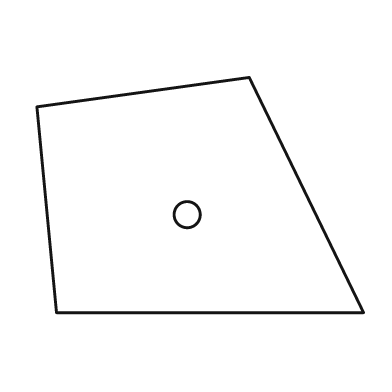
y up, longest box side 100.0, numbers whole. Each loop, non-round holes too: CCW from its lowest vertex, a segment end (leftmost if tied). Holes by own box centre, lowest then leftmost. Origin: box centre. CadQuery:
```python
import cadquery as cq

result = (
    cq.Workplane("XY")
    .moveTo(-44.0, -36.0)
    .lineTo(50.0, -36.0)
    .lineTo(15.0, 36.0)
    .lineTo(-50.0, 27.0)
    .close()
    .moveTo(-4.0, -6.0)
    .circle(4.0)
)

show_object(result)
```